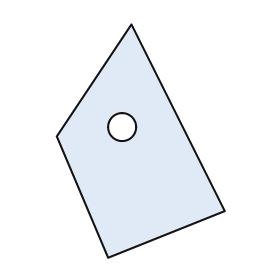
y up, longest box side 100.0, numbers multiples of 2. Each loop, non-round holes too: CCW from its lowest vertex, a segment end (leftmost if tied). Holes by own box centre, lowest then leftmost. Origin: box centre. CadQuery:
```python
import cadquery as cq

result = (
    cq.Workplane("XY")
    .moveTo(-14.0, -50.0)
    .lineTo(36.0, -30.0)
    .lineTo(-4.0, 50.0)
    .lineTo(-36.0, 2.0)
    .close()
    .moveTo(-8.0, 6.0)
    .circle(6.0)
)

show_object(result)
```